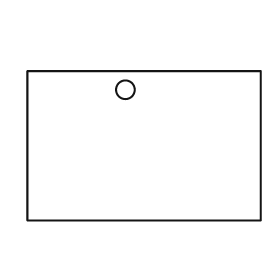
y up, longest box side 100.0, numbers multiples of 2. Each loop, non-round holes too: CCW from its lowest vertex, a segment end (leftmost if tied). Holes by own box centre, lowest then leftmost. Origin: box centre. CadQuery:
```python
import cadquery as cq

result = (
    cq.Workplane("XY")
    .moveTo(-50.0, -32.0)
    .lineTo(50.0, -32.0)
    .lineTo(50.0, 32.0)
    .lineTo(-50.0, 32.0)
    .close()
    .moveTo(-8.0, 24.0)
    .circle(4.0)
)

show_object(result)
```